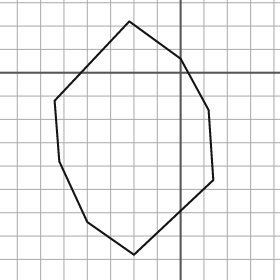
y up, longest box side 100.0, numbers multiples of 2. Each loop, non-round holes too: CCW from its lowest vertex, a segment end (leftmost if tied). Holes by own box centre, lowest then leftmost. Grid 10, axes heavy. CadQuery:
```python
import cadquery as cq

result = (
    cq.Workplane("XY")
    .moveTo(-20.0, -78.0)
    .lineTo(14.0, -46.0)
    .lineTo(12.0, -16.0)
    .lineTo(0.0, 6.0)
    .lineTo(-22.0, 22.0)
    .lineTo(-54.0, -12.0)
    .lineTo(-52.0, -38.0)
    .lineTo(-40.0, -64.0)
    .close()
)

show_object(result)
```